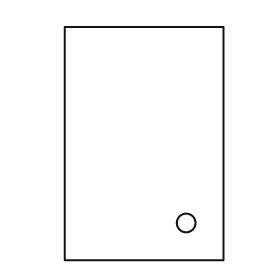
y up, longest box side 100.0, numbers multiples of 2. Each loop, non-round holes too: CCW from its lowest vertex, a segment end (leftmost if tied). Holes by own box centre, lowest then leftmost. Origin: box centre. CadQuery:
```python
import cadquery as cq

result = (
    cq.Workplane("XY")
    .moveTo(-34.0, -50.0)
    .lineTo(34.0, -50.0)
    .lineTo(34.0, 50.0)
    .lineTo(-34.0, 50.0)
    .close()
    .moveTo(18.0, -34.0)
    .circle(4.0)
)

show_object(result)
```